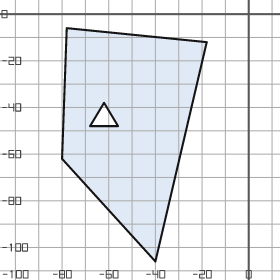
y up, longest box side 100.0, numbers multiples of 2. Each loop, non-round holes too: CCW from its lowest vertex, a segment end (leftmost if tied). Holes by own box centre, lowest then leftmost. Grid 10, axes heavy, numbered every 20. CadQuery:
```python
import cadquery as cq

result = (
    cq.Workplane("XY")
    .moveTo(-40.0, -106.0)
    .lineTo(-18.0, -12.0)
    .lineTo(-78.0, -6.0)
    .lineTo(-80.0, -62.0)
    .close()
    .moveTo(-68.0, -48.0)
    .lineTo(-56.0, -48.0)
    .lineTo(-62.0, -38.0)
    .close()
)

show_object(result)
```